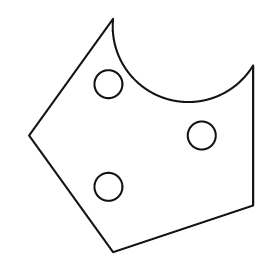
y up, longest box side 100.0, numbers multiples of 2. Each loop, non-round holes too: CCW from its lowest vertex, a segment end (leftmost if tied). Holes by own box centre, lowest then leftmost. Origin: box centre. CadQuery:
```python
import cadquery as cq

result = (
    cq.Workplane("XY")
    .moveTo(-12.0, -50.0)
    .lineTo(48.0, -30.0)
    .lineTo(48.0, 30.0)
    .threePointArc((10.0, 16.0), (-12.0, 50.0))
    .lineTo(-48.0, 0.0)
    .close()
    .moveTo(-14.0, -22.0)
    .circle(6.0)
    .moveTo(26.0, 0.0)
    .circle(6.0)
    .moveTo(-14.0, 22.0)
    .circle(6.0)
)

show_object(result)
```